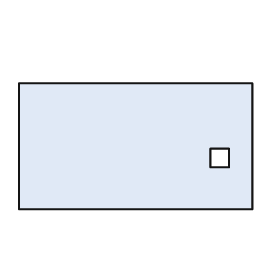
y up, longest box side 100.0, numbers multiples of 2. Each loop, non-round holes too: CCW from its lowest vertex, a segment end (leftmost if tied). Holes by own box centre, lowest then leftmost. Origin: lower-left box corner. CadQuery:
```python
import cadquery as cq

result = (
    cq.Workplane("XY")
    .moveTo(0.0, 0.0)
    .lineTo(100.0, 0.0)
    .lineTo(100.0, 54.0)
    .lineTo(0.0, 54.0)
    .close()
    .moveTo(82.0, 18.0)
    .lineTo(90.0, 18.0)
    .lineTo(90.0, 26.0)
    .lineTo(82.0, 26.0)
    .close()
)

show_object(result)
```